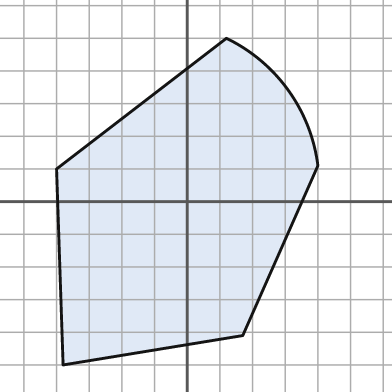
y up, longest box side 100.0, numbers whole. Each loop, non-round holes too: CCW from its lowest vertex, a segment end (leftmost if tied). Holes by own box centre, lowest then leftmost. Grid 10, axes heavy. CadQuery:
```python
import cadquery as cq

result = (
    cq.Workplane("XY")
    .moveTo(-38.0, -50.0)
    .lineTo(17.0, -41.0)
    .lineTo(40.0, 11.0)
    .threePointArc((31.0, 34.0), (12.0, 50.0))
    .lineTo(-40.0, 10.0)
    .close()
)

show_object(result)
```